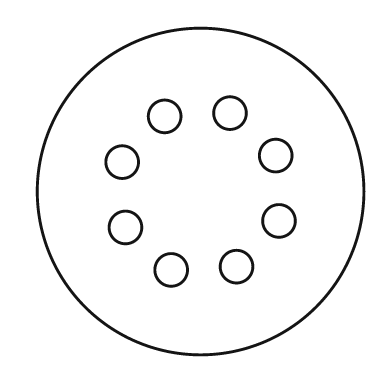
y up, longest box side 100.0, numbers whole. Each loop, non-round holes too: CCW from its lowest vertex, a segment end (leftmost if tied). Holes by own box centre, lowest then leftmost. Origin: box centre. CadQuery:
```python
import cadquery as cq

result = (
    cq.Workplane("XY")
    .moveTo(0.0, 0.0)
    .circle(50.0)
    .moveTo(-9.0, -24.0)
    .circle(5.0)
    .moveTo(11.0, -23.0)
    .circle(5.0)
    .moveTo(-23.0, -11.0)
    .circle(5.0)
    .moveTo(24.0, -9.0)
    .circle(5.0)
    .moveTo(-24.0, 9.0)
    .circle(5.0)
    .moveTo(23.0, 11.0)
    .circle(5.0)
    .moveTo(-11.0, 23.0)
    .circle(5.0)
    .moveTo(9.0, 24.0)
    .circle(5.0)
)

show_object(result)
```